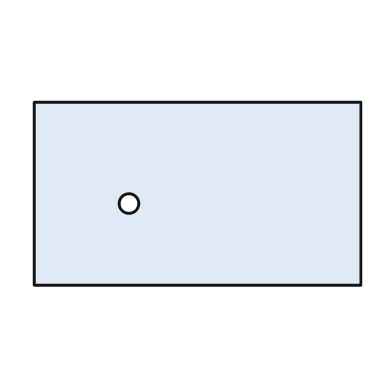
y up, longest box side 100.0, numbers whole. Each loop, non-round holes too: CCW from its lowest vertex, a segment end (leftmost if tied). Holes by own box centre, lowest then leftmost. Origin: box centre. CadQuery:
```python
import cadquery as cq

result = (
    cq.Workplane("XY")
    .moveTo(-50.0, -28.0)
    .lineTo(50.0, -28.0)
    .lineTo(50.0, 28.0)
    .lineTo(-50.0, 28.0)
    .close()
    .moveTo(-21.0, -3.0)
    .circle(3.0)
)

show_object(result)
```